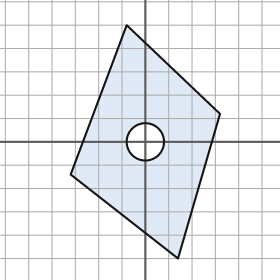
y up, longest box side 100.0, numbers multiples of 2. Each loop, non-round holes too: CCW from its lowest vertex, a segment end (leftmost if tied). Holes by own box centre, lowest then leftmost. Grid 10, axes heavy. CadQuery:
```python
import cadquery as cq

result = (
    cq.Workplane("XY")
    .moveTo(14.0, -50.0)
    .lineTo(32.0, 12.0)
    .lineTo(-8.0, 50.0)
    .lineTo(-32.0, -14.0)
    .close()
    .moveTo(0.0, 0.0)
    .circle(8.0)
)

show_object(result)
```